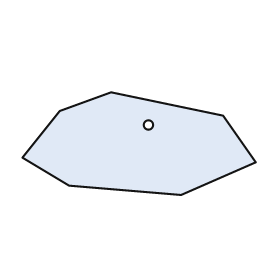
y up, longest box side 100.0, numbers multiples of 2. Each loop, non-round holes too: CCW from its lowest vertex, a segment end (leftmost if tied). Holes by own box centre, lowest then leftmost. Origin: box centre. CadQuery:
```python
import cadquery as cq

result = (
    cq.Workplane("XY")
    .moveTo(18.0, -22.0)
    .lineTo(50.0, -8.0)
    .lineTo(36.0, 12.0)
    .lineTo(-12.0, 22.0)
    .lineTo(-34.0, 14.0)
    .lineTo(-50.0, -6.0)
    .lineTo(-30.0, -18.0)
    .close()
    .moveTo(4.0, 8.0)
    .circle(2.0)
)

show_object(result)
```